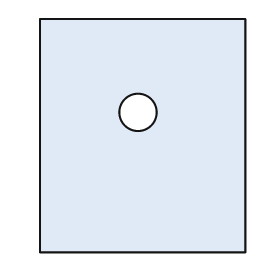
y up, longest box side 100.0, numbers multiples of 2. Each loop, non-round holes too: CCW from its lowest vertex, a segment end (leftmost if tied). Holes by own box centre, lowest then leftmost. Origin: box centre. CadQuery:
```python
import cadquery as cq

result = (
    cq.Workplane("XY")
    .moveTo(-44.0, -50.0)
    .lineTo(44.0, -50.0)
    .lineTo(44.0, 50.0)
    .lineTo(-44.0, 50.0)
    .close()
    .moveTo(-2.0, 10.0)
    .circle(8.0)
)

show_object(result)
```